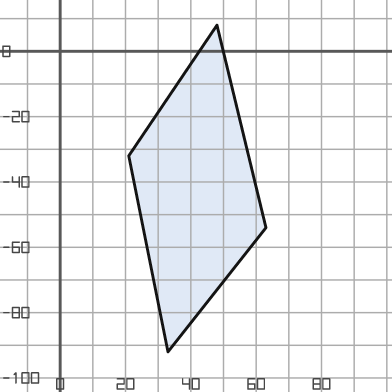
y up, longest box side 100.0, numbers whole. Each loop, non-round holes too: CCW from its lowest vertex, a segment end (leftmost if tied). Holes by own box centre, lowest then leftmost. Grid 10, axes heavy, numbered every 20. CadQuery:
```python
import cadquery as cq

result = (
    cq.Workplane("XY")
    .moveTo(33.0, -92.0)
    .lineTo(63.0, -54.0)
    .lineTo(48.0, 8.0)
    .lineTo(21.0, -32.0)
    .close()
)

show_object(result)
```